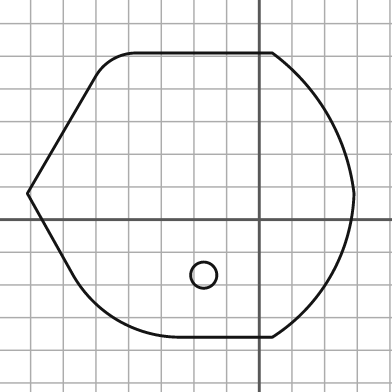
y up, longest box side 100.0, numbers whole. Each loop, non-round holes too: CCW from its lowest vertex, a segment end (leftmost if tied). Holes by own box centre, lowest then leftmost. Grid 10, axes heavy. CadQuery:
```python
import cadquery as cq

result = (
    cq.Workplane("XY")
    .moveTo(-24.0, -36.0)
    .lineTo(4.0, -36.0)
    .threePointArc((22.0, -17.0), (29.0, 8.0))
    .threePointArc((21.0, 32.0), (4.0, 51.0))
    .lineTo(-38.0, 51.0)
    .threePointArc((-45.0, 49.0), (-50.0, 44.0))
    .lineTo(-71.0, 8.0)
    .lineTo(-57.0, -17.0)
    .threePointArc((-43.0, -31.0), (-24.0, -36.0))
    .close()
    .moveTo(-17.0, -17.0)
    .circle(4.0)
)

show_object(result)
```